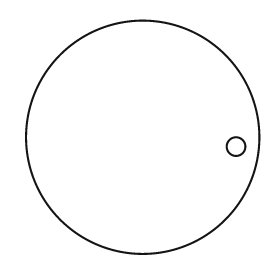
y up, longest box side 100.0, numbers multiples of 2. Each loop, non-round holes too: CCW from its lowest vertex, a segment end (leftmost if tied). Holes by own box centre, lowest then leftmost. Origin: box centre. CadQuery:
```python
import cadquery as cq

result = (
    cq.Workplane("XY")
    .moveTo(0.0, 0.0)
    .circle(50.0)
    .moveTo(40.0, -4.0)
    .circle(4.0)
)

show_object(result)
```